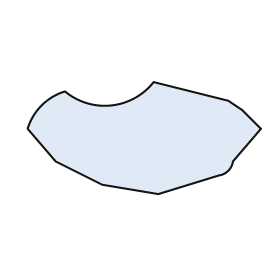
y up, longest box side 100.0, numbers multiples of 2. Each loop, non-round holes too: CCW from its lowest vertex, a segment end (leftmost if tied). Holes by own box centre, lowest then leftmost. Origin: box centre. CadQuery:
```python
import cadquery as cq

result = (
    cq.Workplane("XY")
    .moveTo(6.0, -24.0)
    .lineTo(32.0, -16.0)
    .threePointArc((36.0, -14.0), (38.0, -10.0))
    .lineTo(50.0, 4.0)
    .lineTo(42.0, 12.0)
    .lineTo(36.0, 16.0)
    .lineTo(4.0, 24.0)
    .threePointArc((-14.0, 14.0), (-34.0, 20.0))
    .threePointArc((-44.0, 14.0), (-50.0, 4.0))
    .lineTo(-38.0, -10.0)
    .lineTo(-18.0, -20.0)
    .close()
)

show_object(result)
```